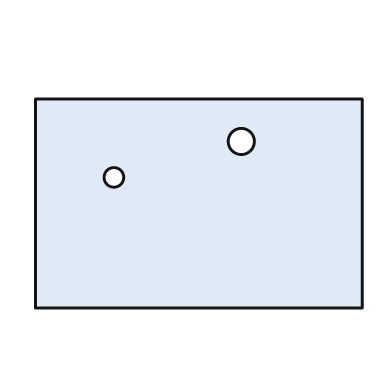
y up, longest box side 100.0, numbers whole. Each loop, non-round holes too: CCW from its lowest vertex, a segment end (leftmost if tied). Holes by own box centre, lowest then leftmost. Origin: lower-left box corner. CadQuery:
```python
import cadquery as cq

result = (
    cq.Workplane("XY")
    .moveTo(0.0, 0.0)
    .lineTo(100.0, 0.0)
    .lineTo(100.0, 64.0)
    .lineTo(0.0, 64.0)
    .close()
    .moveTo(24.0, 40.0)
    .circle(3.0)
    .moveTo(63.0, 51.0)
    .circle(4.0)
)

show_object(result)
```